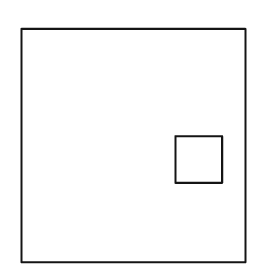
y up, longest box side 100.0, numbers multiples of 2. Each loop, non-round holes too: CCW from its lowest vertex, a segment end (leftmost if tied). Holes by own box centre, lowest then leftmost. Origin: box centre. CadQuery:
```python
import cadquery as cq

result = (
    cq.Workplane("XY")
    .moveTo(-48.0, -50.0)
    .lineTo(48.0, -50.0)
    .lineTo(48.0, 50.0)
    .lineTo(-48.0, 50.0)
    .close()
    .moveTo(18.0, -16.0)
    .lineTo(38.0, -16.0)
    .lineTo(38.0, 4.0)
    .lineTo(18.0, 4.0)
    .close()
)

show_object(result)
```